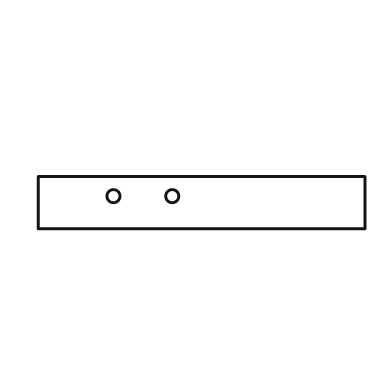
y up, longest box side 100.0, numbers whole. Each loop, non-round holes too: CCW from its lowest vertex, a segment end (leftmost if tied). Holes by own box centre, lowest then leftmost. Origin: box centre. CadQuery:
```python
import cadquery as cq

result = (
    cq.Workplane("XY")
    .moveTo(-50.0, -8.0)
    .lineTo(50.0, -8.0)
    .lineTo(50.0, 8.0)
    .lineTo(-50.0, 8.0)
    .close()
    .moveTo(-27.0, 2.0)
    .circle(2.0)
    .moveTo(-9.0, 2.0)
    .circle(2.0)
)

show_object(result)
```